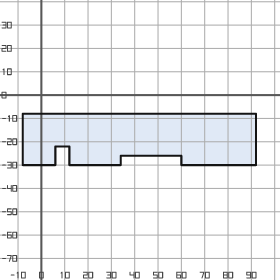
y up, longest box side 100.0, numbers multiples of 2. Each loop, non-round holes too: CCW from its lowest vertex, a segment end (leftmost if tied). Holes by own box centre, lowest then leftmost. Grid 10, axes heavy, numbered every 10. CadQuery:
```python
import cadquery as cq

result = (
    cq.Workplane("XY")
    .moveTo(-8.0, -30.0)
    .lineTo(6.0, -30.0)
    .lineTo(6.0, -22.0)
    .lineTo(12.0, -22.0)
    .lineTo(12.0, -30.0)
    .lineTo(34.0, -30.0)
    .lineTo(34.0, -26.0)
    .lineTo(60.0, -26.0)
    .lineTo(60.0, -30.0)
    .lineTo(92.0, -30.0)
    .lineTo(92.0, -8.0)
    .lineTo(-8.0, -8.0)
    .close()
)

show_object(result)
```